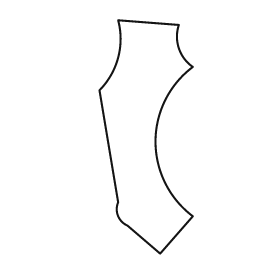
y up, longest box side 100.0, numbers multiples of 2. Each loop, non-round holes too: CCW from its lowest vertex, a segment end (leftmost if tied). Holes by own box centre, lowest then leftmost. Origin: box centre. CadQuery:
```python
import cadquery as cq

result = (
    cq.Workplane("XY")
    .moveTo(6.0, -50.0)
    .lineTo(20.0, -34.0)
    .threePointArc((4.0, -2.0), (20.0, 30.0))
    .threePointArc((14.0, 38.0), (14.0, 48.0))
    .lineTo(-12.0, 50.0)
    .threePointArc((-12.0, 34.0), (-20.0, 20.0))
    .lineTo(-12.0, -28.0)
    .threePointArc((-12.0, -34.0), (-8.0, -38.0))
    .close()
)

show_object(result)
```